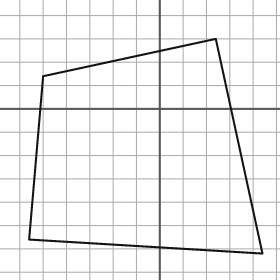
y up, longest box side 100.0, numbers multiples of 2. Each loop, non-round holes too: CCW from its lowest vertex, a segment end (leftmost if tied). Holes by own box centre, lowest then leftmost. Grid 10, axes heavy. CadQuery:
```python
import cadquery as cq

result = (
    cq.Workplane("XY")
    .moveTo(44.0, -62.0)
    .lineTo(24.0, 30.0)
    .lineTo(-50.0, 14.0)
    .lineTo(-56.0, -56.0)
    .close()
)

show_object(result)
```